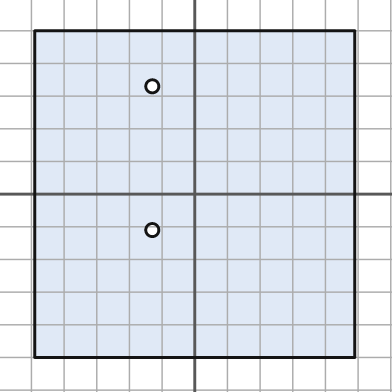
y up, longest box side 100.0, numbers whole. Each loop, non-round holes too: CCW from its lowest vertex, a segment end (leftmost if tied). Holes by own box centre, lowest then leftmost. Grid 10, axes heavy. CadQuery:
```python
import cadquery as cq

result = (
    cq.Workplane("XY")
    .moveTo(-49.0, -50.0)
    .lineTo(49.0, -50.0)
    .lineTo(49.0, 50.0)
    .lineTo(-49.0, 50.0)
    .close()
    .moveTo(-13.0, -11.0)
    .circle(2.0)
    .moveTo(-13.0, 33.0)
    .circle(2.0)
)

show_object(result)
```